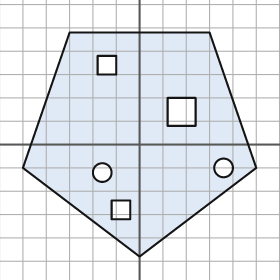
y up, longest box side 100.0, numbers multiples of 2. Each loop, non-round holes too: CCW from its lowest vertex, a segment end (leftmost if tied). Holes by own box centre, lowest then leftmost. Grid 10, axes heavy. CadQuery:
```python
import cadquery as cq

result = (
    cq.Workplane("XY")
    .moveTo(0.0, -48.0)
    .lineTo(50.0, -10.0)
    .lineTo(30.0, 48.0)
    .lineTo(-30.0, 48.0)
    .lineTo(-50.0, -10.0)
    .close()
    .moveTo(-12.0, -32.0)
    .lineTo(-4.0, -32.0)
    .lineTo(-4.0, -24.0)
    .lineTo(-12.0, -24.0)
    .close()
    .moveTo(-16.0, -12.0)
    .circle(4.0)
    .moveTo(36.0, -10.0)
    .circle(4.0)
    .moveTo(12.0, 8.0)
    .lineTo(24.0, 8.0)
    .lineTo(24.0, 20.0)
    .lineTo(12.0, 20.0)
    .close()
    .moveTo(-18.0, 30.0)
    .lineTo(-10.0, 30.0)
    .lineTo(-10.0, 38.0)
    .lineTo(-18.0, 38.0)
    .close()
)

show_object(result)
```